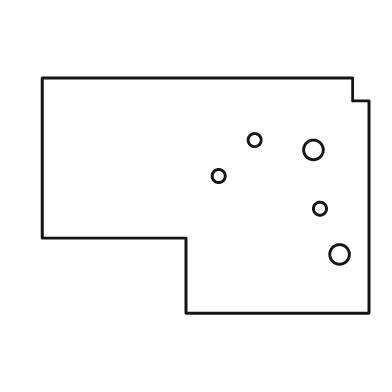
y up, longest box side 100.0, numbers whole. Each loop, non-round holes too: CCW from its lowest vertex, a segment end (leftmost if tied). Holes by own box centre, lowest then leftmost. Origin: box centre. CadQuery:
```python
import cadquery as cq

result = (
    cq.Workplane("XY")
    .moveTo(-6.0, -36.0)
    .lineTo(50.0, -36.0)
    .lineTo(50.0, 29.0)
    .lineTo(45.0, 29.0)
    .lineTo(45.0, 36.0)
    .lineTo(-50.0, 36.0)
    .lineTo(-50.0, -13.0)
    .lineTo(-6.0, -13.0)
    .close()
    .moveTo(41.0, -18.0)
    .circle(3.0)
    .moveTo(35.0, -4.0)
    .circle(2.0)
    .moveTo(4.0, 6.0)
    .circle(2.0)
    .moveTo(33.0, 14.0)
    .circle(3.0)
    .moveTo(15.0, 17.0)
    .circle(2.0)
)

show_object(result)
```